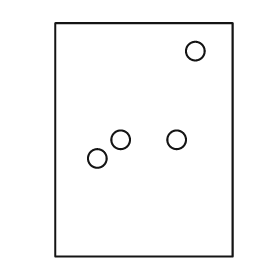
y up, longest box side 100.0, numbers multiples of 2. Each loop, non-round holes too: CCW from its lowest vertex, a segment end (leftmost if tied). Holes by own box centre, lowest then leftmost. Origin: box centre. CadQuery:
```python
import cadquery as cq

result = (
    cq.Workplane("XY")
    .moveTo(-38.0, -50.0)
    .lineTo(38.0, -50.0)
    .lineTo(38.0, 50.0)
    .lineTo(-38.0, 50.0)
    .close()
    .moveTo(-20.0, -8.0)
    .circle(4.0)
    .moveTo(-10.0, 0.0)
    .circle(4.0)
    .moveTo(14.0, 0.0)
    .circle(4.0)
    .moveTo(22.0, 38.0)
    .circle(4.0)
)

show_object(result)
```